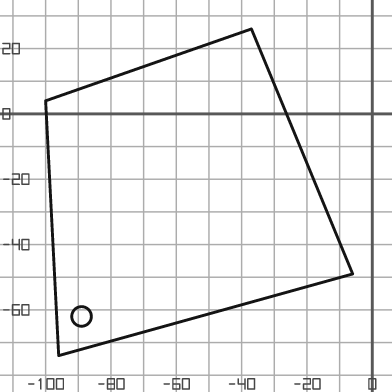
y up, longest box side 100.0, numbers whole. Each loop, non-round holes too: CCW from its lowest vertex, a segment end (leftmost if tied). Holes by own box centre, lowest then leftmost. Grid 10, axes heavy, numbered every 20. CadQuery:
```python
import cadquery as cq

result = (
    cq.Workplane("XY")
    .moveTo(-96.0, -74.0)
    .lineTo(-6.0, -49.0)
    .lineTo(-37.0, 26.0)
    .lineTo(-100.0, 4.0)
    .close()
    .moveTo(-89.0, -62.0)
    .circle(3.0)
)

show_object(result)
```